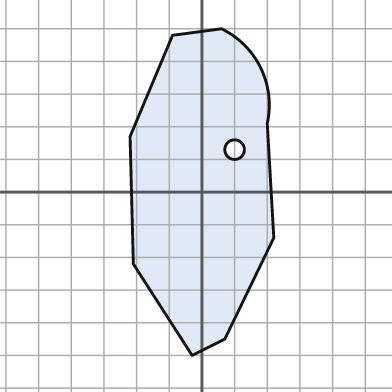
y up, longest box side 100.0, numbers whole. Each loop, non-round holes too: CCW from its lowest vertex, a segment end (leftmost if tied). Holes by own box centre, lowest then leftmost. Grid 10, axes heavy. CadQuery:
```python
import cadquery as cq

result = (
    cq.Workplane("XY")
    .moveTo(-3.0, -50.0)
    .lineTo(7.0, -45.0)
    .lineTo(22.0, -14.0)
    .lineTo(20.0, 21.0)
    .threePointArc((18.0, 38.0), (6.0, 50.0))
    .lineTo(-9.0, 48.0)
    .lineTo(-22.0, 17.0)
    .lineTo(-21.0, -22.0)
    .close()
    .moveTo(10.0, 13.0)
    .circle(3.0)
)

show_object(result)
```